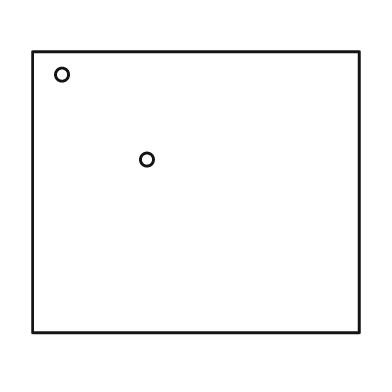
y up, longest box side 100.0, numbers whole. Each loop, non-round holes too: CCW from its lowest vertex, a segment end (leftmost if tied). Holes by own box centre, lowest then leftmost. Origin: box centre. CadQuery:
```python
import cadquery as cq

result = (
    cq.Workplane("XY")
    .moveTo(-50.0, -43.0)
    .lineTo(50.0, -43.0)
    .lineTo(50.0, 43.0)
    .lineTo(-50.0, 43.0)
    .close()
    .moveTo(-15.0, 10.0)
    .circle(2.0)
    .moveTo(-41.0, 36.0)
    .circle(2.0)
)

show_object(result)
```